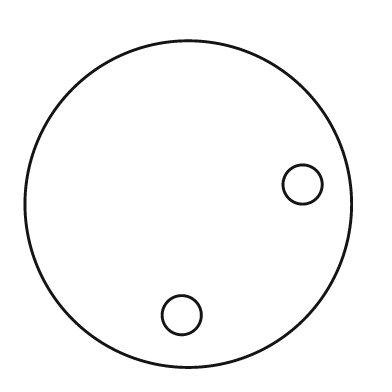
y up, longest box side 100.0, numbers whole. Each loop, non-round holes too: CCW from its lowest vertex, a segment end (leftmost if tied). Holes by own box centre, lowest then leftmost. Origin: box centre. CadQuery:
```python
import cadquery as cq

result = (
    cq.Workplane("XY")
    .moveTo(0.0, 0.0)
    .circle(50.0)
    .moveTo(-2.0, -34.0)
    .circle(6.0)
    .moveTo(35.0, 6.0)
    .circle(6.0)
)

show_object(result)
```